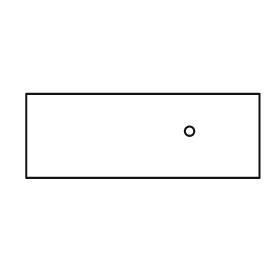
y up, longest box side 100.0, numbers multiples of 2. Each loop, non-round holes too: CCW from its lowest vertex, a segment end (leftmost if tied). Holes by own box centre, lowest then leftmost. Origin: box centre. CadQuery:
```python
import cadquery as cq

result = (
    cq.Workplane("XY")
    .moveTo(-50.0, -18.0)
    .lineTo(50.0, -18.0)
    .lineTo(50.0, 18.0)
    .lineTo(-50.0, 18.0)
    .close()
    .moveTo(20.0, 2.0)
    .circle(2.0)
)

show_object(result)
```